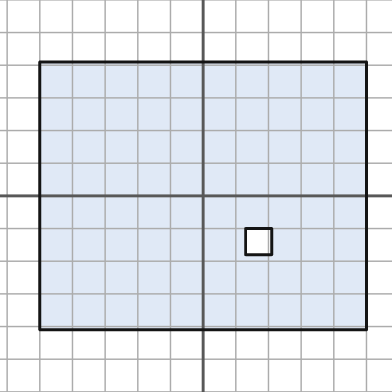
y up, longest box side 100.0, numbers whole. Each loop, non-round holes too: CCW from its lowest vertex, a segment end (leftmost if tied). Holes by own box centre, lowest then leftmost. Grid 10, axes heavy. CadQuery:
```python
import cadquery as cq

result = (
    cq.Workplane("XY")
    .moveTo(-50.0, -41.0)
    .lineTo(50.0, -41.0)
    .lineTo(50.0, 41.0)
    .lineTo(-50.0, 41.0)
    .close()
    .moveTo(13.0, -18.0)
    .lineTo(21.0, -18.0)
    .lineTo(21.0, -10.0)
    .lineTo(13.0, -10.0)
    .close()
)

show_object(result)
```